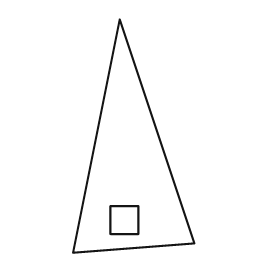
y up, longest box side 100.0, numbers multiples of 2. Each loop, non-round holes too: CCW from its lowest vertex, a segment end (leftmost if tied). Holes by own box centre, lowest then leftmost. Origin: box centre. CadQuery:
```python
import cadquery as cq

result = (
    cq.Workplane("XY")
    .moveTo(-26.0, -50.0)
    .lineTo(26.0, -46.0)
    .lineTo(-6.0, 50.0)
    .close()
    .moveTo(-10.0, -42.0)
    .lineTo(2.0, -42.0)
    .lineTo(2.0, -30.0)
    .lineTo(-10.0, -30.0)
    .close()
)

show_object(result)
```